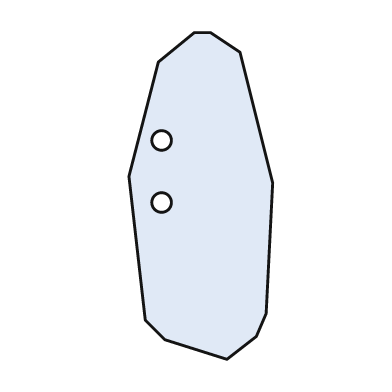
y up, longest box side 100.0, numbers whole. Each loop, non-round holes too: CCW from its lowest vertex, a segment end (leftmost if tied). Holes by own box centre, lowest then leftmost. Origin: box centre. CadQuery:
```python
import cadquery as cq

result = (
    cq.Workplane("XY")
    .moveTo(8.0, -50.0)
    .lineTo(17.0, -43.0)
    .lineTo(20.0, -36.0)
    .lineTo(22.0, 4.0)
    .lineTo(12.0, 44.0)
    .lineTo(3.0, 50.0)
    .lineTo(-2.0, 50.0)
    .lineTo(-13.0, 41.0)
    .lineTo(-22.0, 6.0)
    .lineTo(-17.0, -38.0)
    .lineTo(-11.0, -44.0)
    .close()
    .moveTo(-12.0, -2.0)
    .circle(3.0)
    .moveTo(-12.0, 17.0)
    .circle(3.0)
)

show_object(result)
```